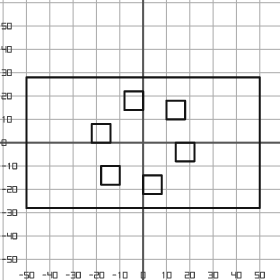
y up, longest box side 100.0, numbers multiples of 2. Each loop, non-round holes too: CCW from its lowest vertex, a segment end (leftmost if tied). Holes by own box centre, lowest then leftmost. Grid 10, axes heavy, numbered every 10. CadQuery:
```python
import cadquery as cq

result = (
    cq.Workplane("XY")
    .moveTo(-50.0, -28.0)
    .lineTo(50.0, -28.0)
    .lineTo(50.0, 28.0)
    .lineTo(-50.0, 28.0)
    .close()
    .moveTo(0.0, -22.0)
    .lineTo(8.0, -22.0)
    .lineTo(8.0, -14.0)
    .lineTo(0.0, -14.0)
    .close()
    .moveTo(-18.0, -18.0)
    .lineTo(-10.0, -18.0)
    .lineTo(-10.0, -10.0)
    .lineTo(-18.0, -10.0)
    .close()
    .moveTo(14.0, -8.0)
    .lineTo(22.0, -8.0)
    .lineTo(22.0, 0.0)
    .lineTo(14.0, 0.0)
    .close()
    .moveTo(-22.0, 0.0)
    .lineTo(-14.0, 0.0)
    .lineTo(-14.0, 8.0)
    .lineTo(-22.0, 8.0)
    .close()
    .moveTo(10.0, 10.0)
    .lineTo(18.0, 10.0)
    .lineTo(18.0, 18.0)
    .lineTo(10.0, 18.0)
    .close()
    .moveTo(-8.0, 14.0)
    .lineTo(0.0, 14.0)
    .lineTo(0.0, 22.0)
    .lineTo(-8.0, 22.0)
    .close()
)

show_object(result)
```